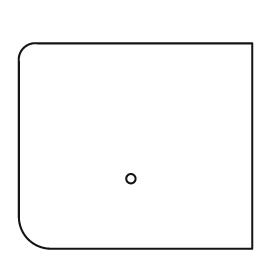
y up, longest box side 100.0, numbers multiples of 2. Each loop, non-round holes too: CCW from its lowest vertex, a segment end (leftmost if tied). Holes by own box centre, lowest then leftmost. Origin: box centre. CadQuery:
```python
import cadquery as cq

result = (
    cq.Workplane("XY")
    .moveTo(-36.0, -44.0)
    .lineTo(50.0, -44.0)
    .lineTo(50.0, 44.0)
    .lineTo(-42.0, 44.0)
    .threePointArc((-48.0, 42.0), (-50.0, 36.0))
    .lineTo(-50.0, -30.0)
    .threePointArc((-46.0, -40.0), (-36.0, -44.0))
    .close()
    .moveTo(-2.0, -14.0)
    .circle(2.0)
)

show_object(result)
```